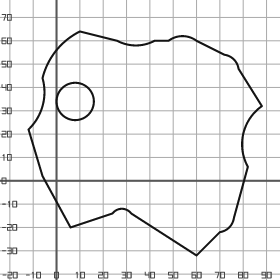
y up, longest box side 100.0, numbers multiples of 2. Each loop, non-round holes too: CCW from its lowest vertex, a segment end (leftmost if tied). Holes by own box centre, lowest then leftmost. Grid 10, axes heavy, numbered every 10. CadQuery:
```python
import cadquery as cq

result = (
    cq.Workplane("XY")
    .moveTo(60.0, -32.0)
    .lineTo(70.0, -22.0)
    .threePointArc((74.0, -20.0), (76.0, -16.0))
    .lineTo(82.0, 6.0)
    .threePointArc((80.0, 20.0), (88.0, 32.0))
    .lineTo(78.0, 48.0)
    .threePointArc((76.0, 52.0), (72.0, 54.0))
    .lineTo(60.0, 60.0)
    .threePointArc((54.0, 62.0), (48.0, 60.0))
    .lineTo(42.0, 60.0)
    .threePointArc((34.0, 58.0), (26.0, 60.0))
    .lineTo(10.0, 64.0)
    .threePointArc((0.0, 56.0), (-6.0, 44.0))
    .threePointArc((-6.0, 32.0), (-12.0, 22.0))
    .lineTo(-6.0, 2.0)
    .lineTo(6.0, -20.0)
    .lineTo(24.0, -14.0)
    .threePointArc((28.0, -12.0), (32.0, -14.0))
    .close()
    .moveTo(8.0, 34.0)
    .circle(8.0)
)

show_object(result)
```